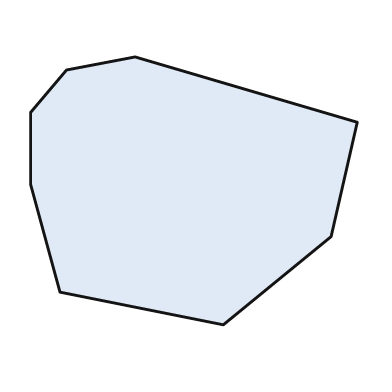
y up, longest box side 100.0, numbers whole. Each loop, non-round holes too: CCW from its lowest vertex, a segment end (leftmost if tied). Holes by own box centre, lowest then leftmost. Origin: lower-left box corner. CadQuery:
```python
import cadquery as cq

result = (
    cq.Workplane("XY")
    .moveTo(59.0, 0.0)
    .lineTo(92.0, 27.0)
    .lineTo(100.0, 62.0)
    .lineTo(32.0, 82.0)
    .lineTo(11.0, 78.0)
    .lineTo(0.0, 65.0)
    .lineTo(0.0, 43.0)
    .lineTo(9.0, 10.0)
    .close()
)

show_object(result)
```